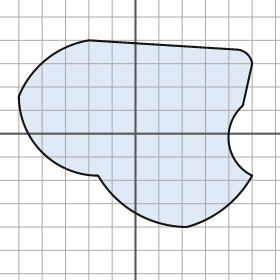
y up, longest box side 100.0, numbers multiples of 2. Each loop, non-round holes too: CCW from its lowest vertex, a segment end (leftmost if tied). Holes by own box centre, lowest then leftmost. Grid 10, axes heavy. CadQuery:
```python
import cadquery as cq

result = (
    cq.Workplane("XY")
    .moveTo(22.0, -40.0)
    .threePointArc((38.0, -32.0), (50.0, -18.0))
    .threePointArc((40.0, -4.0), (46.0, 12.0))
    .lineTo(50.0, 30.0)
    .threePointArc((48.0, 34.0), (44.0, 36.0))
    .lineTo(-20.0, 40.0)
    .threePointArc((-38.0, 32.0), (-50.0, 16.0))
    .threePointArc((-40.0, -8.0), (-16.0, -18.0))
    .threePointArc((0.0, -34.0), (22.0, -40.0))
    .close()
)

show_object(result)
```